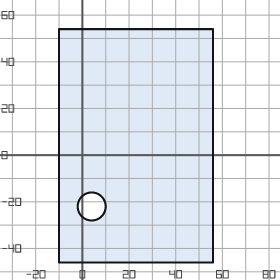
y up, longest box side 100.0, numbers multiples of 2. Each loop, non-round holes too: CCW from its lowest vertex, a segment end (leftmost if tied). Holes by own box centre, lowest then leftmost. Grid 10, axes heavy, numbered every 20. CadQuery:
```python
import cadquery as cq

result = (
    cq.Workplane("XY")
    .moveTo(-10.0, -46.0)
    .lineTo(56.0, -46.0)
    .lineTo(56.0, 54.0)
    .lineTo(-10.0, 54.0)
    .close()
    .moveTo(4.0, -22.0)
    .circle(6.0)
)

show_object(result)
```